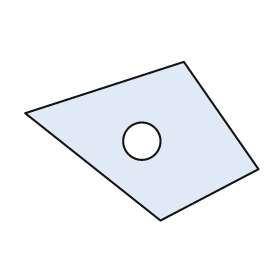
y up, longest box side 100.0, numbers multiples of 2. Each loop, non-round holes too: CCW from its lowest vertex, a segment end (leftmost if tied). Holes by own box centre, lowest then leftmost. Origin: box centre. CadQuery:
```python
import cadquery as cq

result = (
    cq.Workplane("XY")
    .moveTo(8.0, -34.0)
    .lineTo(50.0, -12.0)
    .lineTo(18.0, 34.0)
    .lineTo(-50.0, 12.0)
    .close()
    .moveTo(0.0, 0.0)
    .circle(8.0)
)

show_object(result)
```